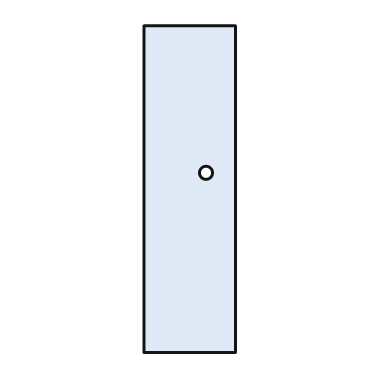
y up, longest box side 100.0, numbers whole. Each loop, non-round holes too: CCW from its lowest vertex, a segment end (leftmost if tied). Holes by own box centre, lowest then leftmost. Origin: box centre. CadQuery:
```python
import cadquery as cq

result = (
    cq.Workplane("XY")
    .moveTo(-14.0, -50.0)
    .lineTo(14.0, -50.0)
    .lineTo(14.0, 50.0)
    .lineTo(-14.0, 50.0)
    .close()
    .moveTo(5.0, 5.0)
    .circle(2.0)
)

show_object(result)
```